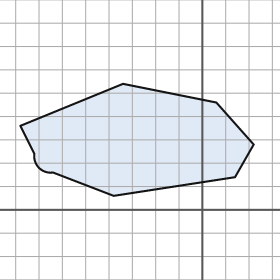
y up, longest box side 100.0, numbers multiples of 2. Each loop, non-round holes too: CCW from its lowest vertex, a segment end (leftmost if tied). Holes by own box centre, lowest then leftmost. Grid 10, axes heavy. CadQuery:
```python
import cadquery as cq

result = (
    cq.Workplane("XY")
    .moveTo(-38.0, 6.0)
    .lineTo(14.0, 14.0)
    .lineTo(22.0, 28.0)
    .lineTo(6.0, 46.0)
    .lineTo(-34.0, 54.0)
    .lineTo(-78.0, 36.0)
    .lineTo(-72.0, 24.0)
    .threePointArc((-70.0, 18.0), (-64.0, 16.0))
    .close()
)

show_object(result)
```